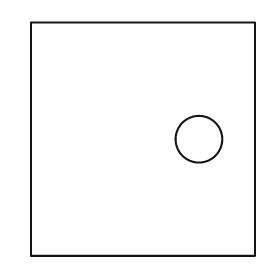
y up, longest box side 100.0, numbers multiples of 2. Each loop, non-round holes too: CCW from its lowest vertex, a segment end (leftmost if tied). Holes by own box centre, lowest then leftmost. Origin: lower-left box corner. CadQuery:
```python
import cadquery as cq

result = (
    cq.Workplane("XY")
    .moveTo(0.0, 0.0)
    .lineTo(96.0, 0.0)
    .lineTo(96.0, 100.0)
    .lineTo(0.0, 100.0)
    .close()
    .moveTo(72.0, 50.0)
    .circle(10.0)
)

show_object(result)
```